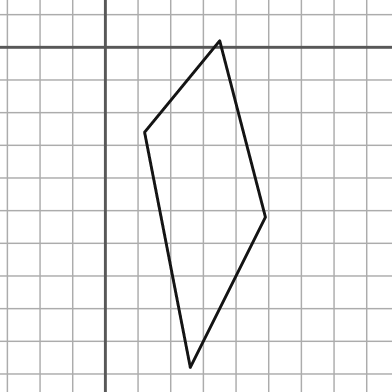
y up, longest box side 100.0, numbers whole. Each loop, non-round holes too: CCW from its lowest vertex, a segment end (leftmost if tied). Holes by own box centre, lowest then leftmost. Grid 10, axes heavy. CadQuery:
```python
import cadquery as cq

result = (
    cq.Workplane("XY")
    .moveTo(26.0, -98.0)
    .lineTo(49.0, -52.0)
    .lineTo(35.0, 2.0)
    .lineTo(12.0, -26.0)
    .close()
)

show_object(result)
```